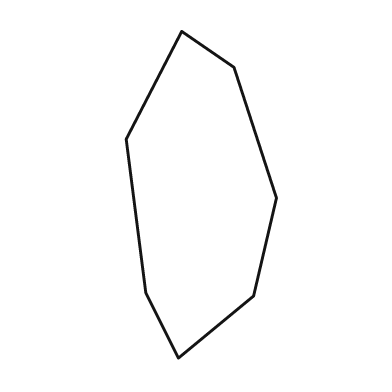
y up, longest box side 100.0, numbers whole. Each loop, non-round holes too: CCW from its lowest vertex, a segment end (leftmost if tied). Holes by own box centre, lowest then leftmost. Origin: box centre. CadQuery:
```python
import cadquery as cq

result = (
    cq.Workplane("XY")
    .moveTo(-7.0, -50.0)
    .lineTo(16.0, -31.0)
    .lineTo(23.0, -1.0)
    .lineTo(10.0, 39.0)
    .lineTo(-6.0, 50.0)
    .lineTo(-23.0, 17.0)
    .lineTo(-17.0, -30.0)
    .close()
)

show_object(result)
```